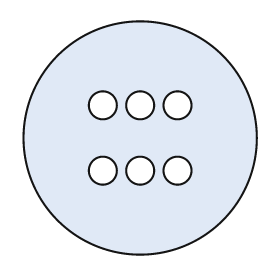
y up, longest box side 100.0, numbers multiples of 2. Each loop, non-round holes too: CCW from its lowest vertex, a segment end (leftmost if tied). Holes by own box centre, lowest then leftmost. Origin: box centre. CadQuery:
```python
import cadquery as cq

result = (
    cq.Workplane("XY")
    .moveTo(0.0, 0.0)
    .circle(50.0)
    .moveTo(-16.0, -14.0)
    .circle(6.0)
    .moveTo(0.0, -14.0)
    .circle(6.0)
    .moveTo(16.0, -14.0)
    .circle(6.0)
    .moveTo(-16.0, 14.0)
    .circle(6.0)
    .moveTo(0.0, 14.0)
    .circle(6.0)
    .moveTo(16.0, 14.0)
    .circle(6.0)
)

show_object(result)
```